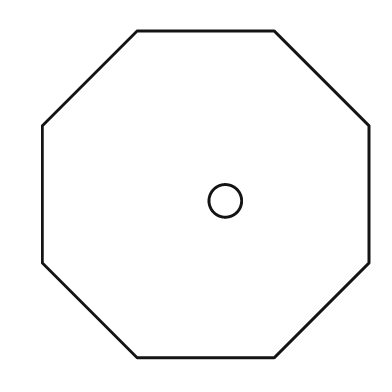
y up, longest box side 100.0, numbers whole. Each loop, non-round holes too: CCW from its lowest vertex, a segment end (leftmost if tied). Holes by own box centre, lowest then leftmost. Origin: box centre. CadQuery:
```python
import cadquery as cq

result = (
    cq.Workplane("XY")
    .moveTo(-21.0, -50.0)
    .lineTo(21.0, -50.0)
    .lineTo(50.0, -21.0)
    .lineTo(50.0, 21.0)
    .lineTo(21.0, 50.0)
    .lineTo(-21.0, 50.0)
    .lineTo(-50.0, 21.0)
    .lineTo(-50.0, -21.0)
    .close()
    .moveTo(6.0, -2.0)
    .circle(5.0)
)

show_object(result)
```